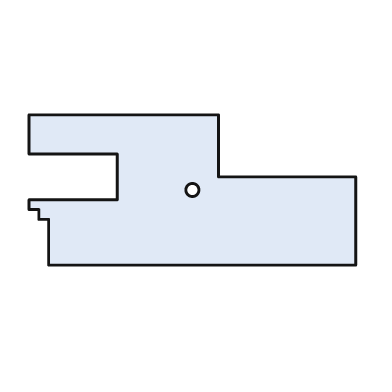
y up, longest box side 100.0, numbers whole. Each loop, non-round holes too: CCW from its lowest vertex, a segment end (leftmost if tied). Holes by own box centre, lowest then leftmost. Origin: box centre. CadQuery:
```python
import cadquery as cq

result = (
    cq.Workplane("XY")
    .moveTo(-44.0, -23.0)
    .lineTo(50.0, -23.0)
    .lineTo(50.0, 4.0)
    .lineTo(8.0, 4.0)
    .lineTo(8.0, 23.0)
    .lineTo(-50.0, 23.0)
    .lineTo(-50.0, 11.0)
    .lineTo(-23.0, 11.0)
    .lineTo(-23.0, -3.0)
    .lineTo(-50.0, -3.0)
    .lineTo(-50.0, -6.0)
    .lineTo(-47.0, -6.0)
    .lineTo(-47.0, -9.0)
    .lineTo(-44.0, -9.0)
    .close()
    .moveTo(0.0, 0.0)
    .circle(2.0)
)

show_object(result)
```